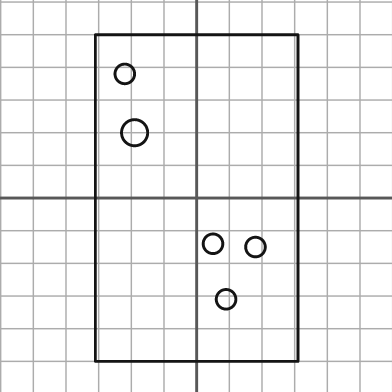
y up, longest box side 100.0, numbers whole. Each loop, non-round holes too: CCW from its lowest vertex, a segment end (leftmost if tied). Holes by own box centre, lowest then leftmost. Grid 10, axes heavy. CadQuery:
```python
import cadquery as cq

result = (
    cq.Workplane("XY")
    .moveTo(-31.0, -50.0)
    .lineTo(31.0, -50.0)
    .lineTo(31.0, 50.0)
    .lineTo(-31.0, 50.0)
    .close()
    .moveTo(9.0, -31.0)
    .circle(3.0)
    .moveTo(18.0, -15.0)
    .circle(3.0)
    .moveTo(5.0, -14.0)
    .circle(3.0)
    .moveTo(-19.0, 20.0)
    .circle(4.0)
    .moveTo(-22.0, 38.0)
    .circle(3.0)
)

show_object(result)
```